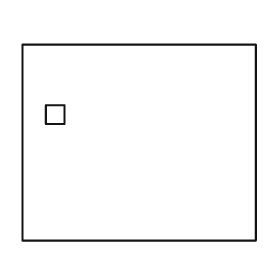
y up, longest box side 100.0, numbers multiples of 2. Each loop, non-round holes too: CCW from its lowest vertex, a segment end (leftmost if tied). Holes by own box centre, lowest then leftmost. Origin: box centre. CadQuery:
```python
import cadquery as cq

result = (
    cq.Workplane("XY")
    .moveTo(-50.0, -42.0)
    .lineTo(50.0, -42.0)
    .lineTo(50.0, 42.0)
    .lineTo(-50.0, 42.0)
    .close()
    .moveTo(-40.0, 8.0)
    .lineTo(-32.0, 8.0)
    .lineTo(-32.0, 16.0)
    .lineTo(-40.0, 16.0)
    .close()
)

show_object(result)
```